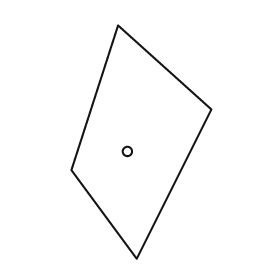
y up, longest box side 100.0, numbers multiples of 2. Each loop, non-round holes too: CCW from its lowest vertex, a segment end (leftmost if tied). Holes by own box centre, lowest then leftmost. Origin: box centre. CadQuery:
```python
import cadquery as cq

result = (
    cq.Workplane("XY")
    .moveTo(-2.0, -50.0)
    .lineTo(30.0, 14.0)
    .lineTo(-10.0, 50.0)
    .lineTo(-30.0, -12.0)
    .close()
    .moveTo(-6.0, -4.0)
    .circle(2.0)
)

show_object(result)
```